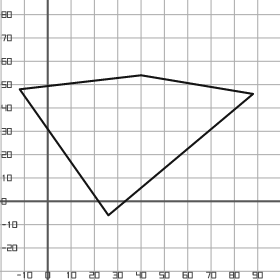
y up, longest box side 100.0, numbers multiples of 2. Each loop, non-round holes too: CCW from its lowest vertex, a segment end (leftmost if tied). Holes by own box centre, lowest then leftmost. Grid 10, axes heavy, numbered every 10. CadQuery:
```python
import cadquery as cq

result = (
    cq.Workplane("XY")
    .moveTo(26.0, -6.0)
    .lineTo(88.0, 46.0)
    .lineTo(40.0, 54.0)
    .lineTo(-12.0, 48.0)
    .close()
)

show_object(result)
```